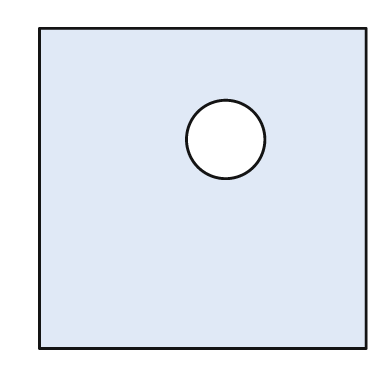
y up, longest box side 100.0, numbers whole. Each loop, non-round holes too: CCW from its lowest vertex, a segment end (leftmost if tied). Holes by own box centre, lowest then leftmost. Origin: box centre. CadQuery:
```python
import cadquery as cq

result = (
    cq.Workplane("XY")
    .moveTo(-50.0, -49.0)
    .lineTo(50.0, -49.0)
    .lineTo(50.0, 49.0)
    .lineTo(-50.0, 49.0)
    .close()
    .moveTo(7.0, 15.0)
    .circle(12.0)
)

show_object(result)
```